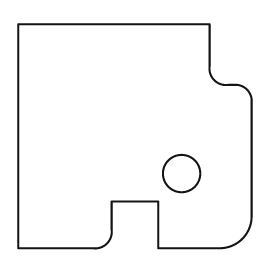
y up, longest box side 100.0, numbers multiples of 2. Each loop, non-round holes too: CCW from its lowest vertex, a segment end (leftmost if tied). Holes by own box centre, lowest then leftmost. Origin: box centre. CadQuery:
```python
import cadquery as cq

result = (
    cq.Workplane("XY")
    .moveTo(-50.0, -48.0)
    .lineTo(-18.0, -48.0)
    .threePointArc((-12.0, -46.0), (-10.0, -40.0))
    .lineTo(-10.0, -28.0)
    .lineTo(10.0, -28.0)
    .lineTo(10.0, -48.0)
    .lineTo(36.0, -48.0)
    .threePointArc((46.0, -44.0), (50.0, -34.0))
    .lineTo(50.0, 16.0)
    .threePointArc((48.0, 20.0), (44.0, 22.0))
    .lineTo(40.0, 22.0)
    .threePointArc((34.0, 24.0), (32.0, 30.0))
    .lineTo(32.0, 48.0)
    .lineTo(-50.0, 48.0)
    .close()
    .moveTo(20.0, -16.0)
    .circle(8.0)
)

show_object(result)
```